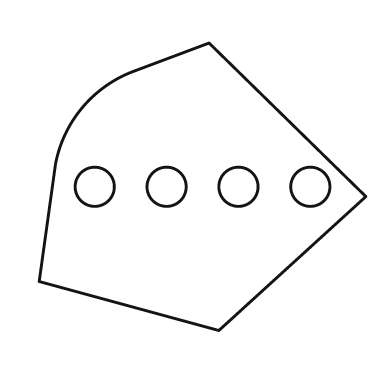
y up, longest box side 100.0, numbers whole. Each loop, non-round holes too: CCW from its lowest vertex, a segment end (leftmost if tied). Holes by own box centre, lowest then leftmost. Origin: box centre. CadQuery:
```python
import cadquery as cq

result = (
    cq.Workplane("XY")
    .moveTo(5.0, -44.0)
    .lineTo(50.0, -3.0)
    .lineTo(2.0, 44.0)
    .lineTo(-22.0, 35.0)
    .threePointArc((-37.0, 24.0), (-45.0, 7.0))
    .lineTo(-50.0, -29.0)
    .close()
    .moveTo(-33.0, 0.0)
    .circle(6.0)
    .moveTo(-11.0, 0.0)
    .circle(6.0)
    .moveTo(11.0, 0.0)
    .circle(6.0)
    .moveTo(33.0, 0.0)
    .circle(6.0)
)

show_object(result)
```